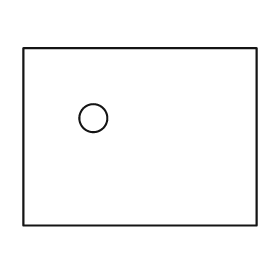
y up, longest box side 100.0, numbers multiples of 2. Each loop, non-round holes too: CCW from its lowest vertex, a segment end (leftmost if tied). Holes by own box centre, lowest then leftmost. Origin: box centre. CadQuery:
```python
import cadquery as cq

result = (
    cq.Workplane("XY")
    .moveTo(-50.0, -38.0)
    .lineTo(50.0, -38.0)
    .lineTo(50.0, 38.0)
    .lineTo(-50.0, 38.0)
    .close()
    .moveTo(-20.0, 8.0)
    .circle(6.0)
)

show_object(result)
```